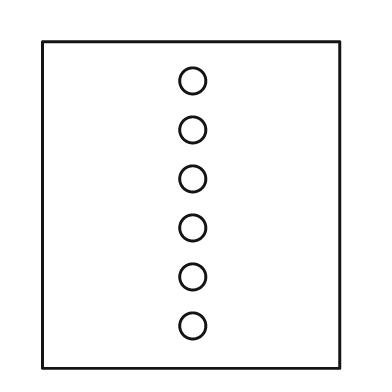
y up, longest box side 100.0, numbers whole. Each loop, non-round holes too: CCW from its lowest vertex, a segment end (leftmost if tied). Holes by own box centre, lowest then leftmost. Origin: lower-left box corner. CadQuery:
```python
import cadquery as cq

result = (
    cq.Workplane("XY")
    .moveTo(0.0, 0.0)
    .lineTo(91.0, 0.0)
    .lineTo(91.0, 100.0)
    .lineTo(0.0, 100.0)
    .close()
    .moveTo(46.0, 13.0)
    .circle(4.0)
    .moveTo(46.0, 28.0)
    .circle(4.0)
    .moveTo(46.0, 43.0)
    .circle(4.0)
    .moveTo(46.0, 58.0)
    .circle(4.0)
    .moveTo(46.0, 73.0)
    .circle(4.0)
    .moveTo(46.0, 88.0)
    .circle(4.0)
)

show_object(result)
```